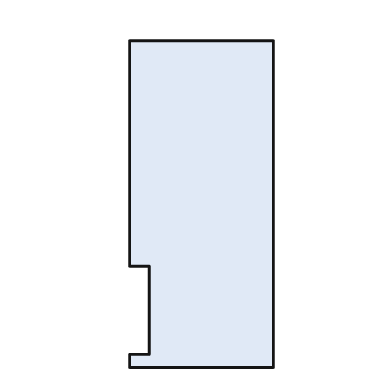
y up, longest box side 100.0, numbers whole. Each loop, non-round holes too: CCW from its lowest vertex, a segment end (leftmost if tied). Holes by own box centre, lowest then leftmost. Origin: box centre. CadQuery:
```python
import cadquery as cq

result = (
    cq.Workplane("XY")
    .moveTo(-22.0, -50.0)
    .lineTo(22.0, -50.0)
    .lineTo(22.0, 50.0)
    .lineTo(-22.0, 50.0)
    .lineTo(-22.0, -19.0)
    .lineTo(-16.0, -19.0)
    .lineTo(-16.0, -46.0)
    .lineTo(-22.0, -46.0)
    .close()
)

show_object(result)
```